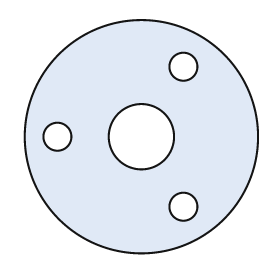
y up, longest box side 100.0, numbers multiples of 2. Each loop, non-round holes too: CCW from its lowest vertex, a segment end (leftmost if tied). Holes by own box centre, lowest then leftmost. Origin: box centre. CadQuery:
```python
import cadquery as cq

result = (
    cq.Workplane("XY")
    .moveTo(0.0, 0.0)
    .circle(50.0)
    .moveTo(18.0, -30.0)
    .circle(6.0)
    .moveTo(-36.0, 0.0)
    .circle(6.0)
    .moveTo(0.0, 0.0)
    .circle(14.0)
    .moveTo(18.0, 30.0)
    .circle(6.0)
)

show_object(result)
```